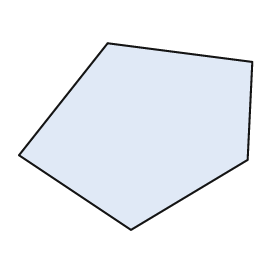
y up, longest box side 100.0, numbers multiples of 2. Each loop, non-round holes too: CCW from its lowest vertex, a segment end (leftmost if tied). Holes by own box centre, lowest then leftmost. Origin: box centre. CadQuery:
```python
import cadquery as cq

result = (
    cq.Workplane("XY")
    .moveTo(-2.0, -40.0)
    .lineTo(48.0, -10.0)
    .lineTo(50.0, 32.0)
    .lineTo(-12.0, 40.0)
    .lineTo(-50.0, -8.0)
    .close()
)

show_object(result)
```